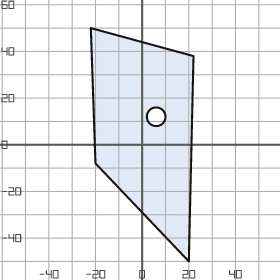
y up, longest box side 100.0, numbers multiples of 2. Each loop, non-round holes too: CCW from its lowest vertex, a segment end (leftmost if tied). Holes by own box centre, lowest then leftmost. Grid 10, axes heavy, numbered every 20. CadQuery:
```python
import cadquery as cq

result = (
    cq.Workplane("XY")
    .moveTo(20.0, -50.0)
    .lineTo(22.0, 38.0)
    .lineTo(-22.0, 50.0)
    .lineTo(-20.0, -8.0)
    .close()
    .moveTo(6.0, 12.0)
    .circle(4.0)
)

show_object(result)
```